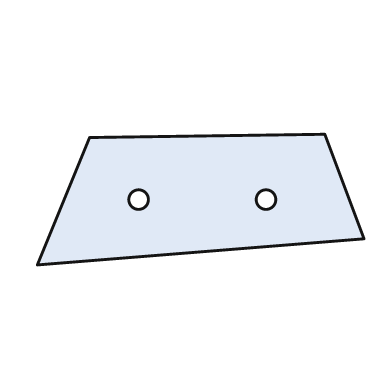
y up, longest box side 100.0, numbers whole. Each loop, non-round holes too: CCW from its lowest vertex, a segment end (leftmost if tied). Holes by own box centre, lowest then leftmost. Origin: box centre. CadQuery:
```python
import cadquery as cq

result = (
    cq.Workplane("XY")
    .moveTo(-50.0, -20.0)
    .lineTo(50.0, -12.0)
    .lineTo(38.0, 20.0)
    .lineTo(-34.0, 19.0)
    .close()
    .moveTo(-19.0, 0.0)
    .circle(3.0)
    .moveTo(20.0, 0.0)
    .circle(3.0)
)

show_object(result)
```